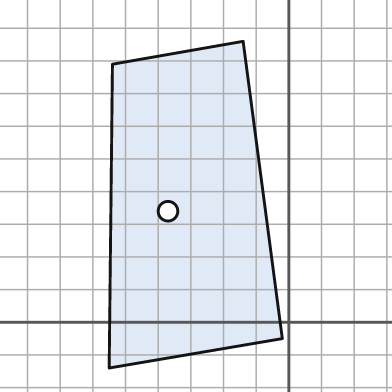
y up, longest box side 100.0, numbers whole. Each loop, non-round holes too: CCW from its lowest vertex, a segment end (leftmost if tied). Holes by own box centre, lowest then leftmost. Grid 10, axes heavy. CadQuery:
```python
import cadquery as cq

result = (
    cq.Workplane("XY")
    .moveTo(-55.0, -14.0)
    .lineTo(-2.0, -5.0)
    .lineTo(-14.0, 86.0)
    .lineTo(-54.0, 79.0)
    .close()
    .moveTo(-37.0, 34.0)
    .circle(3.0)
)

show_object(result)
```